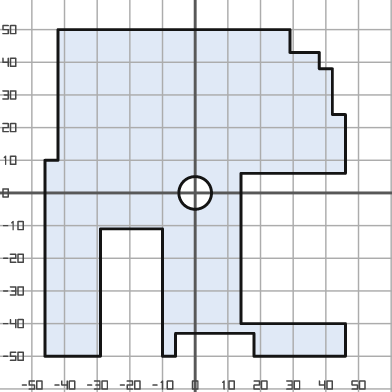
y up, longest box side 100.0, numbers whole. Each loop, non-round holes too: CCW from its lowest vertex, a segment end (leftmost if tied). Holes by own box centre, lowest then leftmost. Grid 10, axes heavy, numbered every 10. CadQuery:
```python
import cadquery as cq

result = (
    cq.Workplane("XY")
    .moveTo(-46.0, -50.0)
    .lineTo(-29.0, -50.0)
    .lineTo(-29.0, -11.0)
    .lineTo(-10.0, -11.0)
    .lineTo(-10.0, -50.0)
    .lineTo(-6.0, -50.0)
    .lineTo(-6.0, -43.0)
    .lineTo(18.0, -43.0)
    .lineTo(18.0, -50.0)
    .lineTo(46.0, -50.0)
    .lineTo(46.0, -40.0)
    .lineTo(14.0, -40.0)
    .lineTo(14.0, 6.0)
    .lineTo(46.0, 6.0)
    .lineTo(46.0, 24.0)
    .lineTo(42.0, 24.0)
    .lineTo(42.0, 38.0)
    .lineTo(38.0, 38.0)
    .lineTo(38.0, 43.0)
    .lineTo(29.0, 43.0)
    .lineTo(29.0, 50.0)
    .lineTo(-42.0, 50.0)
    .lineTo(-42.0, 10.0)
    .lineTo(-46.0, 10.0)
    .close()
    .moveTo(0.0, 0.0)
    .circle(5.0)
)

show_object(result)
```